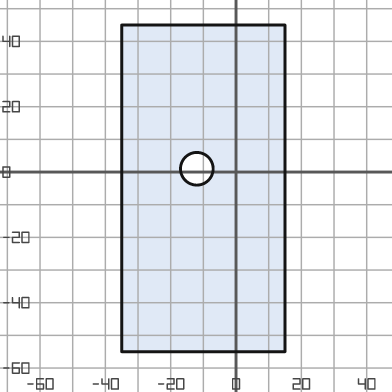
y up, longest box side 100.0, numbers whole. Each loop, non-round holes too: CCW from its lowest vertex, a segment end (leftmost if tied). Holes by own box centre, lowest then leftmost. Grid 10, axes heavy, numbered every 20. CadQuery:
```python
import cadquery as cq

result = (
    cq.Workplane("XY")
    .moveTo(-35.0, -55.0)
    .lineTo(15.0, -55.0)
    .lineTo(15.0, 45.0)
    .lineTo(-35.0, 45.0)
    .close()
    .moveTo(-12.0, 1.0)
    .circle(5.0)
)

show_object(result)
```